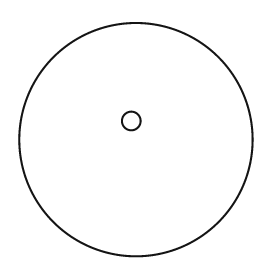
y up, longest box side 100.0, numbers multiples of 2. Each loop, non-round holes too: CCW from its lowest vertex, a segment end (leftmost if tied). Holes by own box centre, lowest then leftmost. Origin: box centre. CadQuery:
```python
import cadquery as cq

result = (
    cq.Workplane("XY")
    .moveTo(0.0, 0.0)
    .circle(50.0)
    .moveTo(-2.0, 8.0)
    .circle(4.0)
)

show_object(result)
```